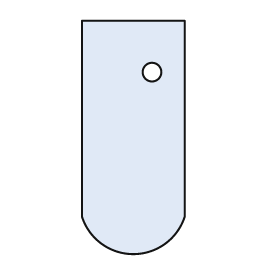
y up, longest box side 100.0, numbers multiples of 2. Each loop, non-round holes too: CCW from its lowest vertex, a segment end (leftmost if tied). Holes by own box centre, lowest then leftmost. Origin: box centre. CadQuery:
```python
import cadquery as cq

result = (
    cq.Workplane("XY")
    .moveTo(-22.0, -34.0)
    .threePointArc((0.0, -50.0), (22.0, -34.0))
    .lineTo(22.0, 50.0)
    .lineTo(-22.0, 50.0)
    .close()
    .moveTo(8.0, 28.0)
    .circle(4.0)
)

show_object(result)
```